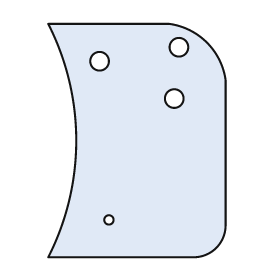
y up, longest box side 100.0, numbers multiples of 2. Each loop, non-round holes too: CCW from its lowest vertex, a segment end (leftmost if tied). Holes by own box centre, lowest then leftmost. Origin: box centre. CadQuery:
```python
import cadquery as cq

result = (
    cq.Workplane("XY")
    .moveTo(-38.0, -50.0)
    .lineTo(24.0, -50.0)
    .threePointArc((34.0, -46.0), (38.0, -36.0))
    .lineTo(38.0, 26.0)
    .threePointArc((30.0, 42.0), (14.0, 50.0))
    .lineTo(-38.0, 50.0)
    .threePointArc((-26.0, 0.0), (-38.0, -50.0))
    .close()
    .moveTo(-12.0, -34.0)
    .circle(2.0)
    .moveTo(16.0, 18.0)
    .circle(4.0)
    .moveTo(-16.0, 34.0)
    .circle(4.0)
    .moveTo(18.0, 40.0)
    .circle(4.0)
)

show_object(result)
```